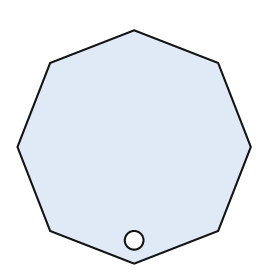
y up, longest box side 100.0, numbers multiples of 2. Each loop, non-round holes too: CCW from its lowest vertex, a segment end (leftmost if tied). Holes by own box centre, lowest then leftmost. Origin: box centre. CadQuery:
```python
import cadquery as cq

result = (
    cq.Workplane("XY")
    .moveTo(0.0, -50.0)
    .lineTo(36.0, -36.0)
    .lineTo(50.0, 0.0)
    .lineTo(36.0, 36.0)
    .lineTo(0.0, 50.0)
    .lineTo(-36.0, 36.0)
    .lineTo(-50.0, 0.0)
    .lineTo(-36.0, -36.0)
    .close()
    .moveTo(0.0, -40.0)
    .circle(4.0)
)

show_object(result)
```